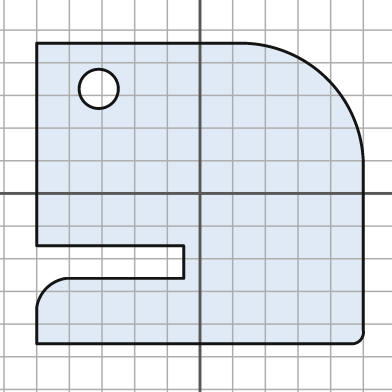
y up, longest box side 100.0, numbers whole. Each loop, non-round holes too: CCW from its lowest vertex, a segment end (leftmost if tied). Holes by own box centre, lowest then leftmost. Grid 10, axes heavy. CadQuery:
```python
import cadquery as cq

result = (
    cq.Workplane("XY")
    .moveTo(-50.0, -46.0)
    .lineTo(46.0, -46.0)
    .threePointArc((49.0, -45.0), (50.0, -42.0))
    .lineTo(50.0, 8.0)
    .threePointArc((39.0, 35.0), (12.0, 46.0))
    .lineTo(-50.0, 46.0)
    .lineTo(-50.0, -16.0)
    .lineTo(-5.0, -16.0)
    .lineTo(-5.0, -26.0)
    .lineTo(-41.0, -26.0)
    .threePointArc((-47.0, -29.0), (-50.0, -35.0))
    .close()
    .moveTo(-31.0, 32.0)
    .circle(6.0)
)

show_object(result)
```